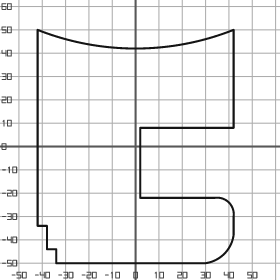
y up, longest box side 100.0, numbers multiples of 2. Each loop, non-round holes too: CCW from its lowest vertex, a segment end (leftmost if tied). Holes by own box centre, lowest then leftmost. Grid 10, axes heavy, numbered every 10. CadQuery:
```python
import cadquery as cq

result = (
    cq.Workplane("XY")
    .moveTo(-34.0, -50.0)
    .lineTo(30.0, -50.0)
    .threePointArc((38.0, -46.0), (42.0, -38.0))
    .lineTo(42.0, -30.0)
    .threePointArc((40.0, -24.0), (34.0, -22.0))
    .lineTo(2.0, -22.0)
    .lineTo(2.0, 8.0)
    .lineTo(42.0, 8.0)
    .lineTo(42.0, 50.0)
    .threePointArc((0.0, 42.0), (-42.0, 50.0))
    .lineTo(-42.0, -34.0)
    .lineTo(-38.0, -34.0)
    .lineTo(-38.0, -44.0)
    .lineTo(-34.0, -44.0)
    .close()
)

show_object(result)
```